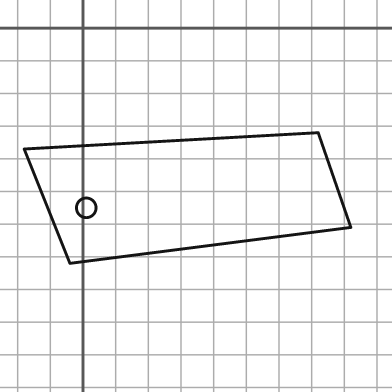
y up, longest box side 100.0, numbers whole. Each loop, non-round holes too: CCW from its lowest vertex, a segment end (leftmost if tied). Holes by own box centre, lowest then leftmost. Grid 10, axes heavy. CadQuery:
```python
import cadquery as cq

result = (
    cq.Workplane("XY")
    .moveTo(-4.0, -72.0)
    .lineTo(82.0, -61.0)
    .lineTo(72.0, -32.0)
    .lineTo(-18.0, -37.0)
    .close()
    .moveTo(1.0, -55.0)
    .circle(3.0)
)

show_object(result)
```